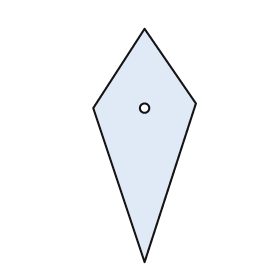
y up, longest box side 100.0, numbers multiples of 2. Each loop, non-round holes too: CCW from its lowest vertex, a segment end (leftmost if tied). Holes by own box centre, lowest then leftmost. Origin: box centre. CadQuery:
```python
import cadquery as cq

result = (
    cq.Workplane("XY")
    .moveTo(0.0, -50.0)
    .lineTo(22.0, 18.0)
    .lineTo(0.0, 50.0)
    .lineTo(-22.0, 16.0)
    .close()
    .moveTo(0.0, 16.0)
    .circle(2.0)
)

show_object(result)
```